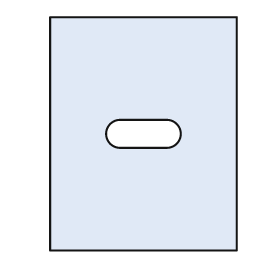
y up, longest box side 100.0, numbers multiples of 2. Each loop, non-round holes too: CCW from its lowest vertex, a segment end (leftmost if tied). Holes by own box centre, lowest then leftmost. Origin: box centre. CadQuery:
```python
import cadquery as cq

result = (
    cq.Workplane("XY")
    .moveTo(-40.0, -50.0)
    .lineTo(40.0, -50.0)
    .lineTo(40.0, 50.0)
    .lineTo(-40.0, 50.0)
    .close()
    .moveTo(-10.0, -6.0)
    .lineTo(10.0, -6.0)
    .threePointArc((16.0, 0.0), (10.0, 6.0))
    .lineTo(-10.0, 6.0)
    .threePointArc((-16.0, 0.0), (-10.0, -6.0))
    .close()
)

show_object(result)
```